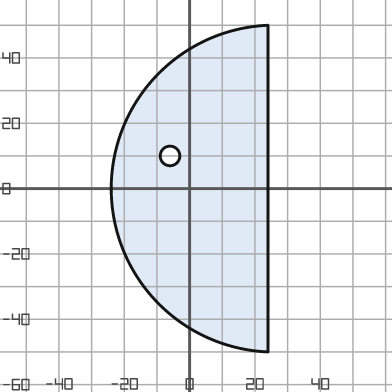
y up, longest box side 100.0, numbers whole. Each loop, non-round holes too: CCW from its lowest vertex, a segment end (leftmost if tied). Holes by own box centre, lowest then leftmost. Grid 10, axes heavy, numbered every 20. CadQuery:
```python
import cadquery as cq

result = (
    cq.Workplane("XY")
    .moveTo(24.0, -50.0)
    .lineTo(24.0, 50.0)
    .threePointArc((-24.0, 0.0), (24.0, -50.0))
    .close()
    .moveTo(-6.0, 10.0)
    .circle(3.0)
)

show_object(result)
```